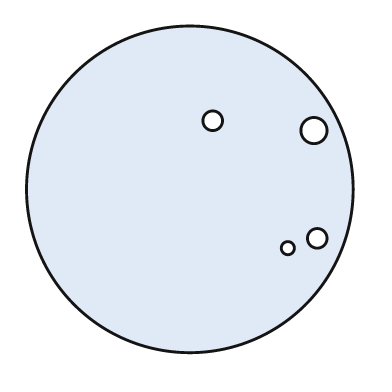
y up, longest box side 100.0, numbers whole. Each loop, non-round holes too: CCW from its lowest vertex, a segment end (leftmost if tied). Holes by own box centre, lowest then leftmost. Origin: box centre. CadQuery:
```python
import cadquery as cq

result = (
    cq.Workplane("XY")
    .moveTo(0.0, 0.0)
    .circle(50.0)
    .moveTo(30.0, -18.0)
    .circle(2.0)
    .moveTo(39.0, -15.0)
    .circle(3.0)
    .moveTo(38.0, 18.0)
    .circle(4.0)
    .moveTo(7.0, 21.0)
    .circle(3.0)
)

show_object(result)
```